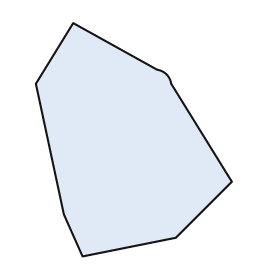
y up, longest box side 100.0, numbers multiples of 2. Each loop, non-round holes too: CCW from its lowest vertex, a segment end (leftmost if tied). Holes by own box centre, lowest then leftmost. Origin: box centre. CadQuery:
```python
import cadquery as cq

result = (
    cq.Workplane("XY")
    .moveTo(-22.0, -50.0)
    .lineTo(18.0, -42.0)
    .lineTo(42.0, -18.0)
    .lineTo(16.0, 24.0)
    .threePointArc((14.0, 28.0), (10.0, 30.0))
    .lineTo(-26.0, 50.0)
    .lineTo(-42.0, 24.0)
    .lineTo(-30.0, -32.0)
    .close()
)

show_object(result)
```